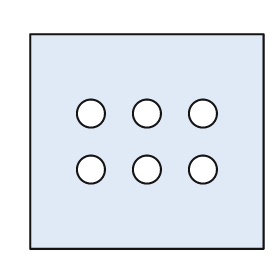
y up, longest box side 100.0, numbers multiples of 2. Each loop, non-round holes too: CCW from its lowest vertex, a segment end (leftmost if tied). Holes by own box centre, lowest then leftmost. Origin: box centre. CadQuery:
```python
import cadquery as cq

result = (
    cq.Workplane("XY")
    .moveTo(-50.0, -46.0)
    .lineTo(50.0, -46.0)
    .lineTo(50.0, 46.0)
    .lineTo(-50.0, 46.0)
    .close()
    .moveTo(-24.0, -12.0)
    .circle(6.0)
    .moveTo(0.0, -12.0)
    .circle(6.0)
    .moveTo(24.0, -12.0)
    .circle(6.0)
    .moveTo(-24.0, 12.0)
    .circle(6.0)
    .moveTo(0.0, 12.0)
    .circle(6.0)
    .moveTo(24.0, 12.0)
    .circle(6.0)
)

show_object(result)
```